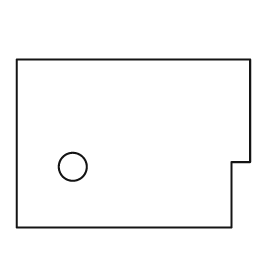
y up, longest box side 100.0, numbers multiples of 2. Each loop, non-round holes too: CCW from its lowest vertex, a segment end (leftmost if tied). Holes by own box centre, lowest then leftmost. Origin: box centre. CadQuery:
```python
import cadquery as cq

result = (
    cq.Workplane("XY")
    .moveTo(-50.0, -36.0)
    .lineTo(42.0, -36.0)
    .lineTo(42.0, -8.0)
    .lineTo(50.0, -8.0)
    .lineTo(50.0, 36.0)
    .lineTo(-50.0, 36.0)
    .close()
    .moveTo(-26.0, -10.0)
    .circle(6.0)
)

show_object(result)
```